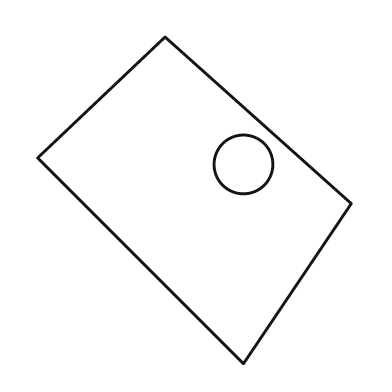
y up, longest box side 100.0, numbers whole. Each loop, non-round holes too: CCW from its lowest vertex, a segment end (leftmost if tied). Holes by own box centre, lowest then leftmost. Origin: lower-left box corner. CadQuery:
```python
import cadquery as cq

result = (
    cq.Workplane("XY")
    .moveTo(63.0, 0.0)
    .lineTo(96.0, 49.0)
    .lineTo(39.0, 100.0)
    .lineTo(0.0, 63.0)
    .close()
    .moveTo(63.0, 61.0)
    .circle(9.0)
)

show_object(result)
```